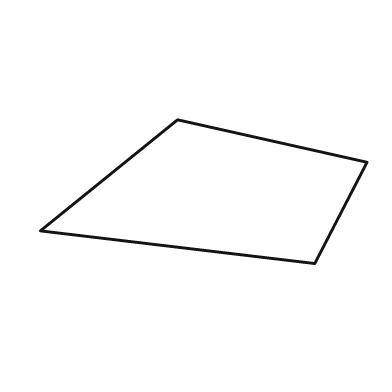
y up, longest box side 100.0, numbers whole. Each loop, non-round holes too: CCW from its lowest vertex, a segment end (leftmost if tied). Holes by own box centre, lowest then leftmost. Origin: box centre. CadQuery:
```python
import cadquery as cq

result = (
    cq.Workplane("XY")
    .moveTo(34.0, -22.0)
    .lineTo(50.0, 9.0)
    .lineTo(-8.0, 22.0)
    .lineTo(-50.0, -12.0)
    .close()
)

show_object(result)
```